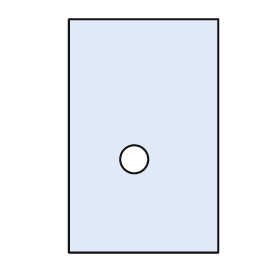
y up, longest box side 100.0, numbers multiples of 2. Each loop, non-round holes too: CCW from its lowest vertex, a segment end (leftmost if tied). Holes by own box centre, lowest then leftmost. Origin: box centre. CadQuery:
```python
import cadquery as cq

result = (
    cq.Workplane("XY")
    .moveTo(-32.0, -50.0)
    .lineTo(32.0, -50.0)
    .lineTo(32.0, 50.0)
    .lineTo(-32.0, 50.0)
    .close()
    .moveTo(-4.0, -10.0)
    .circle(6.0)
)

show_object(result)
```